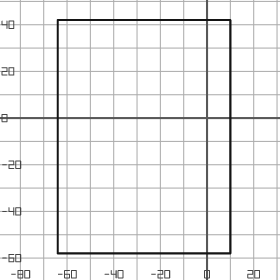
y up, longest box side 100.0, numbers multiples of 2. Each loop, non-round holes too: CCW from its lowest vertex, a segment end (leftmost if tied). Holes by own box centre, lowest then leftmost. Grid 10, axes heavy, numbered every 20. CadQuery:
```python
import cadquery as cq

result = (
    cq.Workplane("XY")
    .moveTo(-64.0, -58.0)
    .lineTo(10.0, -58.0)
    .lineTo(10.0, 42.0)
    .lineTo(-64.0, 42.0)
    .close()
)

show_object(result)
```